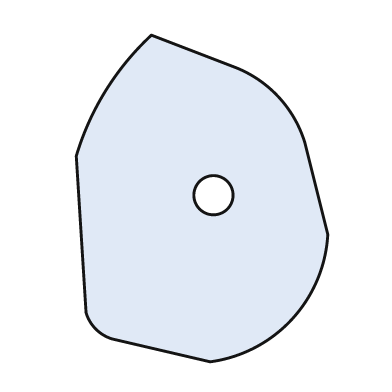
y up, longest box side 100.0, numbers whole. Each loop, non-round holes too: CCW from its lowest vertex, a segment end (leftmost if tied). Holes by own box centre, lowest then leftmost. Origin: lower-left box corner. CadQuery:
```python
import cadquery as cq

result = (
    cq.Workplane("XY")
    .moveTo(41.0, 0.0)
    .threePointArc((66.0, 13.0), (77.0, 39.0))
    .lineTo(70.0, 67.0)
    .threePointArc((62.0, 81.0), (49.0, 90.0))
    .lineTo(23.0, 100.0)
    .threePointArc((9.0, 83.0), (0.0, 63.0))
    .lineTo(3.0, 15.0)
    .threePointArc((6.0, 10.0), (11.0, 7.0))
    .close()
    .moveTo(42.0, 51.0)
    .circle(6.0)
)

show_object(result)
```